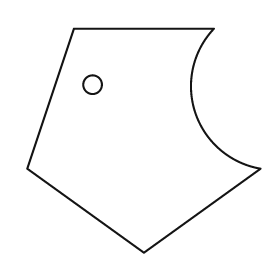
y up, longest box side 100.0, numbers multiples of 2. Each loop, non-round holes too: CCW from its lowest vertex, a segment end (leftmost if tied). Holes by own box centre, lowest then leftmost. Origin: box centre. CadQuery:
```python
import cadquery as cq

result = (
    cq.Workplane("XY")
    .moveTo(0.0, -48.0)
    .lineTo(50.0, -12.0)
    .threePointArc((22.0, 12.0), (30.0, 48.0))
    .lineTo(-30.0, 48.0)
    .lineTo(-50.0, -12.0)
    .close()
    .moveTo(-22.0, 24.0)
    .circle(4.0)
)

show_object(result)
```